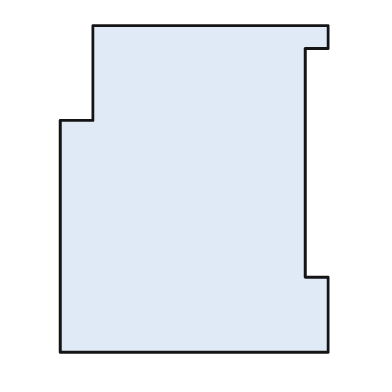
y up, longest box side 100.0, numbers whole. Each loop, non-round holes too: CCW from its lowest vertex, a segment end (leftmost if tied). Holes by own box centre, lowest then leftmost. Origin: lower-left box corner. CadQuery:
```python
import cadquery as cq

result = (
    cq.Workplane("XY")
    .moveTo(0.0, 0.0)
    .lineTo(82.0, 0.0)
    .lineTo(82.0, 23.0)
    .lineTo(75.0, 23.0)
    .lineTo(75.0, 93.0)
    .lineTo(82.0, 93.0)
    .lineTo(82.0, 100.0)
    .lineTo(10.0, 100.0)
    .lineTo(10.0, 71.0)
    .lineTo(0.0, 71.0)
    .close()
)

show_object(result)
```